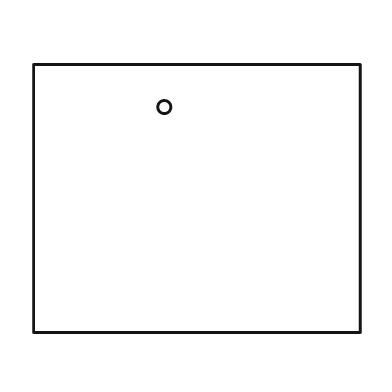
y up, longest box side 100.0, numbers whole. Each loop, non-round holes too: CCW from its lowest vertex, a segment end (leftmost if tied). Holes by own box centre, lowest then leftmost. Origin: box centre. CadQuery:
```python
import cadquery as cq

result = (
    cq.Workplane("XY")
    .moveTo(-50.0, -41.0)
    .lineTo(50.0, -41.0)
    .lineTo(50.0, 41.0)
    .lineTo(-50.0, 41.0)
    .close()
    .moveTo(-10.0, 28.0)
    .circle(2.0)
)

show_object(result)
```